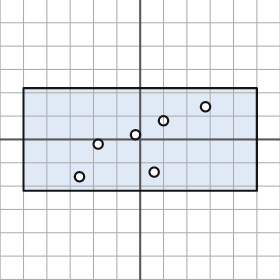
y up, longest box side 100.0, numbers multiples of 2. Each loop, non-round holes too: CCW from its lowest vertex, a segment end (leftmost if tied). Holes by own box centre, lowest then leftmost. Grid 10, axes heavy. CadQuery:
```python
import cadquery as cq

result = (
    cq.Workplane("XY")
    .moveTo(-50.0, -22.0)
    .lineTo(50.0, -22.0)
    .lineTo(50.0, 22.0)
    .lineTo(-50.0, 22.0)
    .close()
    .moveTo(-26.0, -16.0)
    .circle(2.0)
    .moveTo(6.0, -14.0)
    .circle(2.0)
    .moveTo(-18.0, -2.0)
    .circle(2.0)
    .moveTo(-2.0, 2.0)
    .circle(2.0)
    .moveTo(10.0, 8.0)
    .circle(2.0)
    .moveTo(28.0, 14.0)
    .circle(2.0)
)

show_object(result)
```